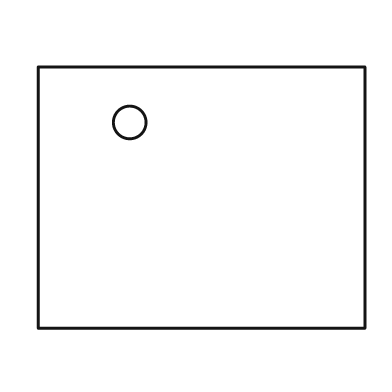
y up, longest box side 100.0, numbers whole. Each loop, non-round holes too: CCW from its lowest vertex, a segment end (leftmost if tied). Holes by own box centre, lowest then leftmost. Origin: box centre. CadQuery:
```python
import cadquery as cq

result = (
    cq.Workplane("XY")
    .moveTo(-50.0, -40.0)
    .lineTo(50.0, -40.0)
    .lineTo(50.0, 40.0)
    .lineTo(-50.0, 40.0)
    .close()
    .moveTo(-22.0, 23.0)
    .circle(5.0)
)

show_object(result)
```